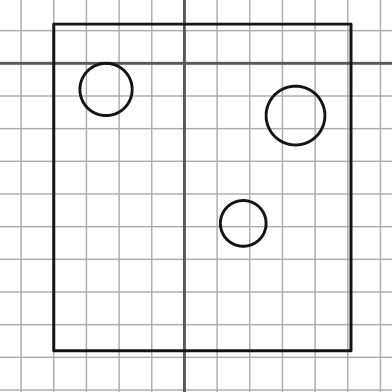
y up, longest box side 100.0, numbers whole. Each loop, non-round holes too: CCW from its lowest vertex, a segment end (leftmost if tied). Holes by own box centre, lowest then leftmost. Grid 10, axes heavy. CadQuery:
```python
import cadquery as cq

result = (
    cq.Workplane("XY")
    .moveTo(-40.0, -88.0)
    .lineTo(51.0, -88.0)
    .lineTo(51.0, 12.0)
    .lineTo(-40.0, 12.0)
    .close()
    .moveTo(18.0, -49.0)
    .circle(7.0)
    .moveTo(34.0, -16.0)
    .circle(9.0)
    .moveTo(-24.0, -8.0)
    .circle(8.0)
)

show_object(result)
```